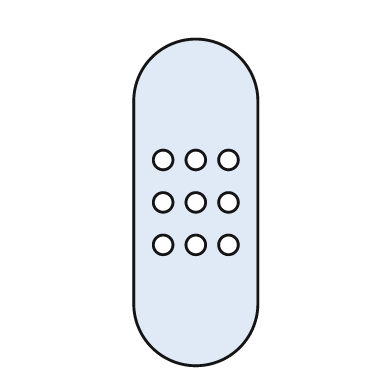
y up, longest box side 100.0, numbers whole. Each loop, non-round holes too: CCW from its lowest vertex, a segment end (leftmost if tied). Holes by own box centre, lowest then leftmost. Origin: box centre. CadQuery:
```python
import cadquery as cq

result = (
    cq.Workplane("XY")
    .moveTo(-19.0, -31.0)
    .threePointArc((0.0, -50.0), (19.0, -31.0))
    .lineTo(19.0, 31.0)
    .threePointArc((0.0, 50.0), (-19.0, 31.0))
    .close()
    .moveTo(-10.0, -13.0)
    .circle(3.0)
    .moveTo(0.0, -13.0)
    .circle(3.0)
    .moveTo(10.0, -13.0)
    .circle(3.0)
    .moveTo(-10.0, 0.0)
    .circle(3.0)
    .moveTo(0.0, 0.0)
    .circle(3.0)
    .moveTo(10.0, 0.0)
    .circle(3.0)
    .moveTo(-10.0, 13.0)
    .circle(3.0)
    .moveTo(0.0, 13.0)
    .circle(3.0)
    .moveTo(10.0, 13.0)
    .circle(3.0)
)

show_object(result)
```